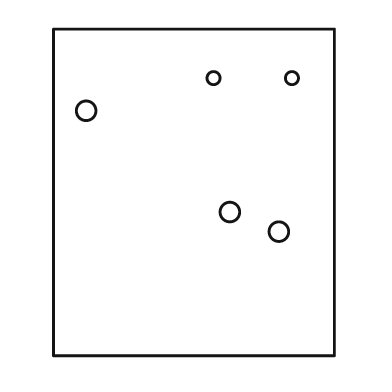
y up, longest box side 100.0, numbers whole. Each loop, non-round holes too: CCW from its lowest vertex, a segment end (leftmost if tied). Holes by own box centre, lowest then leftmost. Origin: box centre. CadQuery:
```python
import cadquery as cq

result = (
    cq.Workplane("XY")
    .moveTo(-43.0, -50.0)
    .lineTo(43.0, -50.0)
    .lineTo(43.0, 50.0)
    .lineTo(-43.0, 50.0)
    .close()
    .moveTo(26.0, -12.0)
    .circle(3.0)
    .moveTo(11.0, -6.0)
    .circle(3.0)
    .moveTo(-33.0, 25.0)
    .circle(3.0)
    .moveTo(6.0, 35.0)
    .circle(2.0)
    .moveTo(30.0, 35.0)
    .circle(2.0)
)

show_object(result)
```